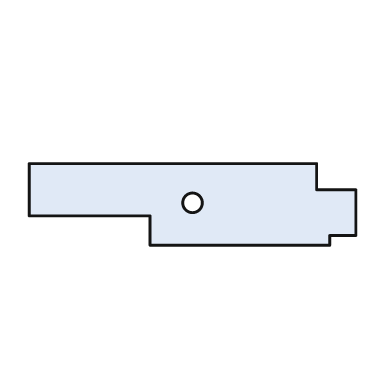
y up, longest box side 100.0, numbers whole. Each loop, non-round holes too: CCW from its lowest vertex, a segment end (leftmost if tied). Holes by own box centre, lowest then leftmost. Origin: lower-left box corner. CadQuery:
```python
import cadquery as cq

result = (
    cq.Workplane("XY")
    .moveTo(37.0, 0.0)
    .lineTo(92.0, 0.0)
    .lineTo(92.0, 3.0)
    .lineTo(100.0, 3.0)
    .lineTo(100.0, 17.0)
    .lineTo(88.0, 17.0)
    .lineTo(88.0, 25.0)
    .lineTo(0.0, 25.0)
    .lineTo(0.0, 9.0)
    .lineTo(37.0, 9.0)
    .close()
    .moveTo(50.0, 13.0)
    .circle(3.0)
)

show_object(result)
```